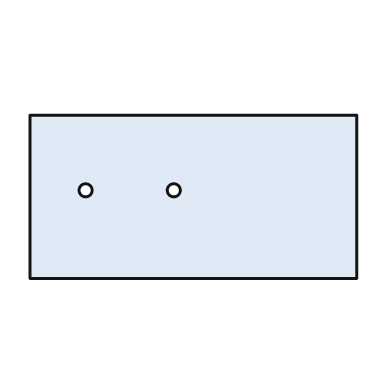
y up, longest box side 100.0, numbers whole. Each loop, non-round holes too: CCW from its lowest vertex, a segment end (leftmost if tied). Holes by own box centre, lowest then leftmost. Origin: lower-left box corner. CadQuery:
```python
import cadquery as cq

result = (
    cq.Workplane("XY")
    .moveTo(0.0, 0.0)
    .lineTo(100.0, 0.0)
    .lineTo(100.0, 50.0)
    .lineTo(0.0, 50.0)
    .close()
    .moveTo(17.0, 27.0)
    .circle(2.0)
    .moveTo(44.0, 27.0)
    .circle(2.0)
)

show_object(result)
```